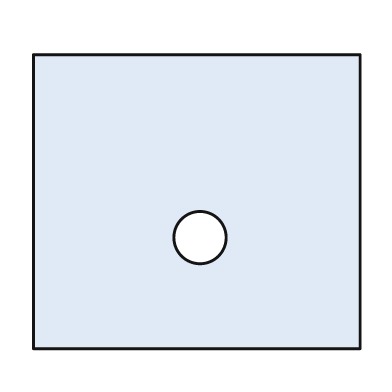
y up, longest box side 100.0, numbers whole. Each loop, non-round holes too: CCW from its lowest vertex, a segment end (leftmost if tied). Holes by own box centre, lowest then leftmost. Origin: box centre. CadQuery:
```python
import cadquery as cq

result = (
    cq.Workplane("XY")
    .moveTo(-50.0, -45.0)
    .lineTo(50.0, -45.0)
    .lineTo(50.0, 45.0)
    .lineTo(-50.0, 45.0)
    .close()
    .moveTo(1.0, -11.0)
    .circle(8.0)
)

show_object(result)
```